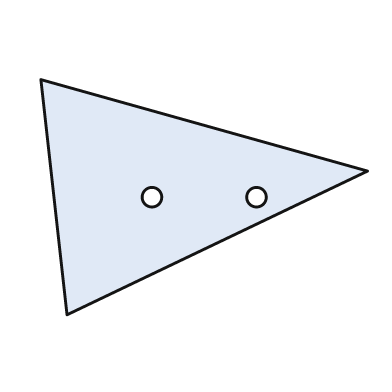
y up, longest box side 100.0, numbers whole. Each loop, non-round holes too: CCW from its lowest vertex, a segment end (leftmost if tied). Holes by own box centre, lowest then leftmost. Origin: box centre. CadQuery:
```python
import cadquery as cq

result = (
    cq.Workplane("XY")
    .moveTo(-42.0, -36.0)
    .lineTo(50.0, 8.0)
    .lineTo(-50.0, 36.0)
    .close()
    .moveTo(-16.0, 0.0)
    .circle(3.0)
    .moveTo(16.0, 0.0)
    .circle(3.0)
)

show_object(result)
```